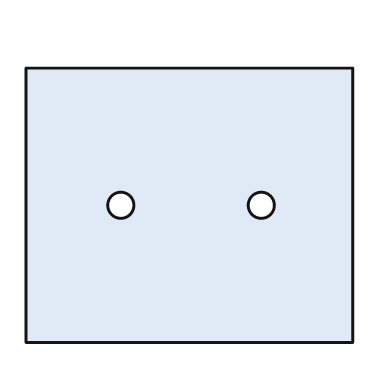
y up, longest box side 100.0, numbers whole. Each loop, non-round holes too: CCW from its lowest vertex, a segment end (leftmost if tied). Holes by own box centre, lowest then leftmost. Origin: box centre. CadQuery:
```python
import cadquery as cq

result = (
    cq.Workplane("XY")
    .moveTo(-50.0, -42.0)
    .lineTo(50.0, -42.0)
    .lineTo(50.0, 42.0)
    .lineTo(-50.0, 42.0)
    .close()
    .moveTo(-21.0, 0.0)
    .circle(4.0)
    .moveTo(22.0, 0.0)
    .circle(4.0)
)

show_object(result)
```